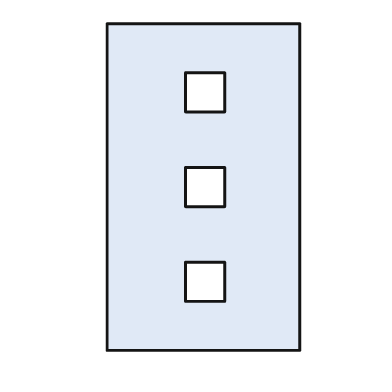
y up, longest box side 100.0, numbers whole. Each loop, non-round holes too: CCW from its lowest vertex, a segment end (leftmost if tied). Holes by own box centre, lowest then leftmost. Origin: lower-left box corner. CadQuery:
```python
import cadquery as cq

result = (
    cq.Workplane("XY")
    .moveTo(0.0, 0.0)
    .lineTo(59.0, 0.0)
    .lineTo(59.0, 100.0)
    .lineTo(0.0, 100.0)
    .close()
    .moveTo(24.0, 15.0)
    .lineTo(36.0, 15.0)
    .lineTo(36.0, 27.0)
    .lineTo(24.0, 27.0)
    .close()
    .moveTo(24.0, 44.0)
    .lineTo(36.0, 44.0)
    .lineTo(36.0, 56.0)
    .lineTo(24.0, 56.0)
    .close()
    .moveTo(24.0, 73.0)
    .lineTo(36.0, 73.0)
    .lineTo(36.0, 85.0)
    .lineTo(24.0, 85.0)
    .close()
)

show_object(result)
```